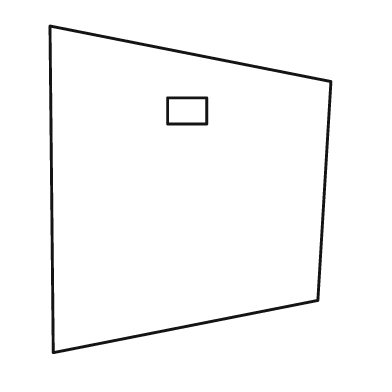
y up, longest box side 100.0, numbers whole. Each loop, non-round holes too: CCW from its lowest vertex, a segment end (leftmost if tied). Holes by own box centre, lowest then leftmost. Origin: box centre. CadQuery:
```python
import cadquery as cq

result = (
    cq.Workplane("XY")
    .moveTo(-42.0, -50.0)
    .lineTo(39.0, -34.0)
    .lineTo(43.0, 33.0)
    .lineTo(-43.0, 50.0)
    .close()
    .moveTo(-7.0, 20.0)
    .lineTo(5.0, 20.0)
    .lineTo(5.0, 28.0)
    .lineTo(-7.0, 28.0)
    .close()
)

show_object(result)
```